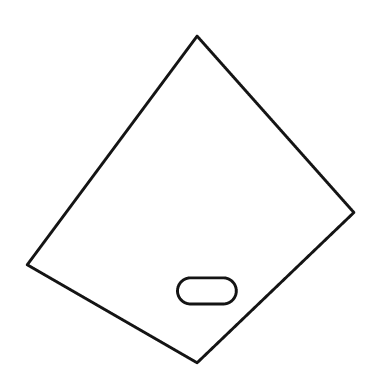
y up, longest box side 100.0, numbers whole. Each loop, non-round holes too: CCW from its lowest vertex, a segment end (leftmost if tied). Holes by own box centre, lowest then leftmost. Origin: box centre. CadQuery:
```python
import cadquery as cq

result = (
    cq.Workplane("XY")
    .moveTo(2.0, -50.0)
    .lineTo(50.0, -4.0)
    .lineTo(2.0, 50.0)
    .lineTo(-50.0, -20.0)
    .close()
    .moveTo(0.0, -32.0)
    .lineTo(10.0, -32.0)
    .threePointArc((14.0, -28.0), (10.0, -24.0))
    .lineTo(0.0, -24.0)
    .threePointArc((-4.0, -28.0), (0.0, -32.0))
    .close()
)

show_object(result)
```